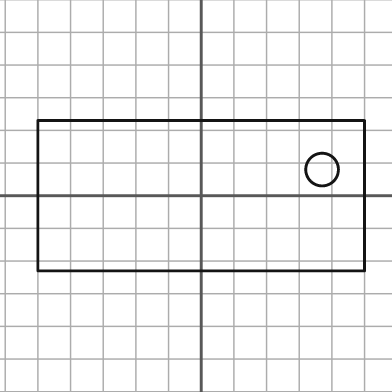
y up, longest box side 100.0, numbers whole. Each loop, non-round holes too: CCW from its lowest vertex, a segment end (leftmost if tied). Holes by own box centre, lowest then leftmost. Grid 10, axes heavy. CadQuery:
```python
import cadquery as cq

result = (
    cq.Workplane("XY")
    .moveTo(-50.0, -23.0)
    .lineTo(50.0, -23.0)
    .lineTo(50.0, 23.0)
    .lineTo(-50.0, 23.0)
    .close()
    .moveTo(37.0, 8.0)
    .circle(5.0)
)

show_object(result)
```